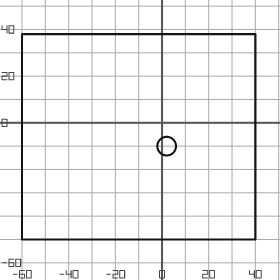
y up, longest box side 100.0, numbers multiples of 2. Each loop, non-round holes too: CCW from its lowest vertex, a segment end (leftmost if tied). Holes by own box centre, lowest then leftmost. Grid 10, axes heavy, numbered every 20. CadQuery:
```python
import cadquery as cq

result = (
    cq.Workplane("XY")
    .moveTo(-60.0, -50.0)
    .lineTo(40.0, -50.0)
    .lineTo(40.0, 38.0)
    .lineTo(-60.0, 38.0)
    .close()
    .moveTo(2.0, -10.0)
    .circle(4.0)
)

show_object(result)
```